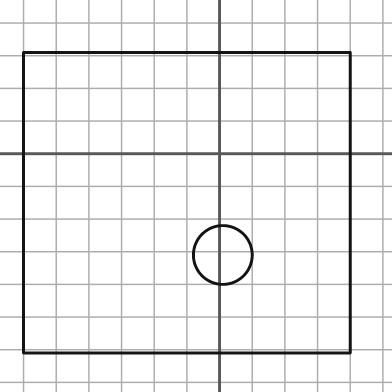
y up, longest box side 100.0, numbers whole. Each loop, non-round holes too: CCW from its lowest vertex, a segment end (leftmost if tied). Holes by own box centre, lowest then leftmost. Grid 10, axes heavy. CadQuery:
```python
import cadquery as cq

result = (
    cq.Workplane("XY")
    .moveTo(-60.0, -61.0)
    .lineTo(40.0, -61.0)
    .lineTo(40.0, 31.0)
    .lineTo(-60.0, 31.0)
    .close()
    .moveTo(1.0, -31.0)
    .circle(9.0)
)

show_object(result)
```